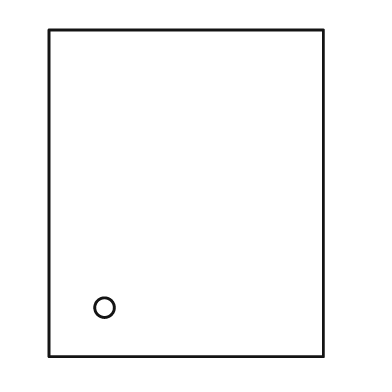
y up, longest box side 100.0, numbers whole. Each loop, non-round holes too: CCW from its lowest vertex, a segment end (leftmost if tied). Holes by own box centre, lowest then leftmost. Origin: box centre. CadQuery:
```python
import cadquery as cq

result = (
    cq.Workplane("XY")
    .moveTo(-42.0, -50.0)
    .lineTo(42.0, -50.0)
    .lineTo(42.0, 50.0)
    .lineTo(-42.0, 50.0)
    .close()
    .moveTo(-25.0, -35.0)
    .circle(3.0)
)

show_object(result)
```